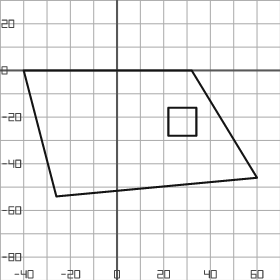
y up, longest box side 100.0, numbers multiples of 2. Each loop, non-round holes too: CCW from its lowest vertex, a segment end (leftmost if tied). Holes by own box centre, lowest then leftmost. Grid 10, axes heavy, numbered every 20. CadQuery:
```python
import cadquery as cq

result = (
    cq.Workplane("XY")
    .moveTo(-26.0, -54.0)
    .lineTo(60.0, -46.0)
    .lineTo(32.0, 0.0)
    .lineTo(-40.0, 0.0)
    .close()
    .moveTo(22.0, -28.0)
    .lineTo(34.0, -28.0)
    .lineTo(34.0, -16.0)
    .lineTo(22.0, -16.0)
    .close()
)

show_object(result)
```